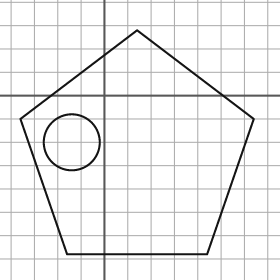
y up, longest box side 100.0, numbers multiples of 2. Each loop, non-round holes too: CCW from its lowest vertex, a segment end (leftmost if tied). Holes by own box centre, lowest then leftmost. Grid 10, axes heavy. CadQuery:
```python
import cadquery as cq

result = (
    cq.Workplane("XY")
    .moveTo(-16.0, -68.0)
    .lineTo(44.0, -68.0)
    .lineTo(64.0, -10.0)
    .lineTo(14.0, 28.0)
    .lineTo(-36.0, -10.0)
    .close()
    .moveTo(-14.0, -20.0)
    .circle(12.0)
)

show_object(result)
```